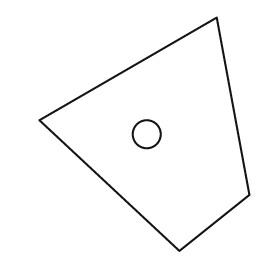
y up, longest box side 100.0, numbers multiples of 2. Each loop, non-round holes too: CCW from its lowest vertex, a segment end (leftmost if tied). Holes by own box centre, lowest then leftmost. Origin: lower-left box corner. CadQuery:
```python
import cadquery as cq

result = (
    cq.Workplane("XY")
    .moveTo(60.0, 0.0)
    .lineTo(90.0, 24.0)
    .lineTo(76.0, 100.0)
    .lineTo(0.0, 56.0)
    .close()
    .moveTo(46.0, 50.0)
    .circle(6.0)
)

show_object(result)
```